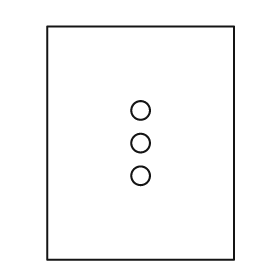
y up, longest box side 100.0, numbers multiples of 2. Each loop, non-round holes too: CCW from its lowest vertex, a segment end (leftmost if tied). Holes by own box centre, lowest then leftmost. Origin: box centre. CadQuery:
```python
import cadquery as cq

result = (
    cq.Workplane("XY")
    .moveTo(-40.0, -50.0)
    .lineTo(40.0, -50.0)
    .lineTo(40.0, 50.0)
    .lineTo(-40.0, 50.0)
    .close()
    .moveTo(0.0, -14.0)
    .circle(4.0)
    .moveTo(0.0, 0.0)
    .circle(4.0)
    .moveTo(0.0, 14.0)
    .circle(4.0)
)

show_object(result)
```